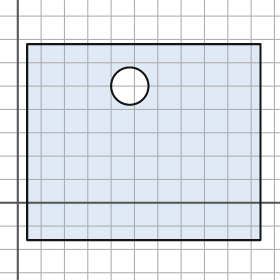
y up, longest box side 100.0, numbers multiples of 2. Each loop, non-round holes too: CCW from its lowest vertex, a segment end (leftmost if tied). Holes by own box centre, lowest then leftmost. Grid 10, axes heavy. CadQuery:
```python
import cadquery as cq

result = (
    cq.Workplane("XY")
    .moveTo(4.0, -16.0)
    .lineTo(104.0, -16.0)
    .lineTo(104.0, 68.0)
    .lineTo(4.0, 68.0)
    .close()
    .moveTo(48.0, 50.0)
    .circle(8.0)
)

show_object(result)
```